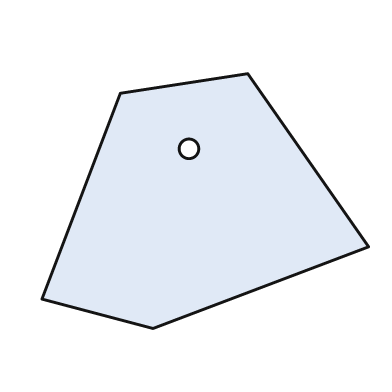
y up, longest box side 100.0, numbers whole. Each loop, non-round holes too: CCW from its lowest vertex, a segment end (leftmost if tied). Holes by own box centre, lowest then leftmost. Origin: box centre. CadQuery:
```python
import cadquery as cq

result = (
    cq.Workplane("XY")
    .moveTo(-16.0, -39.0)
    .lineTo(50.0, -14.0)
    .lineTo(13.0, 39.0)
    .lineTo(-26.0, 33.0)
    .lineTo(-50.0, -30.0)
    .close()
    .moveTo(-5.0, 16.0)
    .circle(3.0)
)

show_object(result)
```